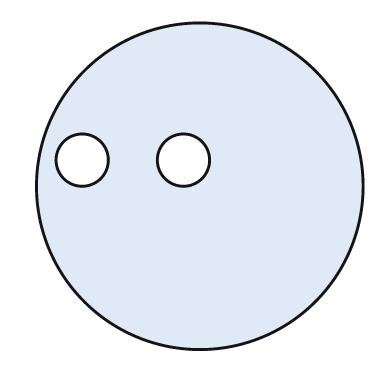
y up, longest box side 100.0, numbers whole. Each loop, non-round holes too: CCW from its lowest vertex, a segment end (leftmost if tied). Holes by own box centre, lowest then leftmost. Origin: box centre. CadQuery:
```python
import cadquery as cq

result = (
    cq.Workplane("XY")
    .moveTo(0.0, 0.0)
    .circle(50.0)
    .moveTo(-36.0, 8.0)
    .circle(8.0)
    .moveTo(-5.0, 8.0)
    .circle(8.0)
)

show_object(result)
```